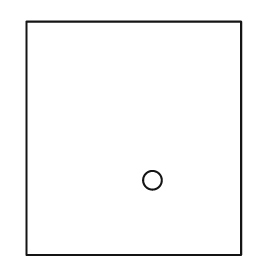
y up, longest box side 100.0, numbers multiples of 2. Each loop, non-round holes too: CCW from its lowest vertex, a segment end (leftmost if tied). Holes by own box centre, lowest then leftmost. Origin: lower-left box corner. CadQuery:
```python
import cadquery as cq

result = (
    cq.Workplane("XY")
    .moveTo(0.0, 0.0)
    .lineTo(92.0, 0.0)
    .lineTo(92.0, 100.0)
    .lineTo(0.0, 100.0)
    .close()
    .moveTo(54.0, 32.0)
    .circle(4.0)
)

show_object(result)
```